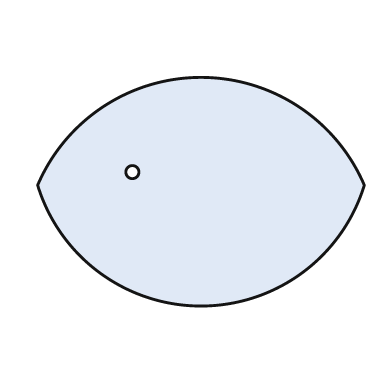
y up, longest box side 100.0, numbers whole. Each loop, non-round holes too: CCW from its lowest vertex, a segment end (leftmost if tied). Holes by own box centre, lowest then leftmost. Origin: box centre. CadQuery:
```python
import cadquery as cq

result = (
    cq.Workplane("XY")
    .moveTo(-50.0, 2.0)
    .threePointArc((0.0, -35.0), (50.0, 2.0))
    .threePointArc((0.0, 35.0), (-50.0, 2.0))
    .close()
    .moveTo(-21.0, 6.0)
    .circle(2.0)
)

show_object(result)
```